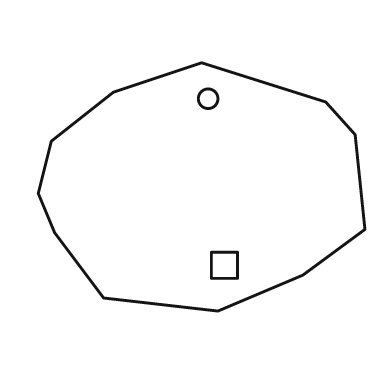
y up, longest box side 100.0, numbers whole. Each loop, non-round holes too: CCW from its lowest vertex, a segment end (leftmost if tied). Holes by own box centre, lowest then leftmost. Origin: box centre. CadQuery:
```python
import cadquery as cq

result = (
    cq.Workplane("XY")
    .moveTo(5.0, -38.0)
    .lineTo(31.0, -27.0)
    .lineTo(50.0, -13.0)
    .lineTo(47.0, 16.0)
    .lineTo(38.0, 26.0)
    .lineTo(0.0, 38.0)
    .lineTo(-27.0, 29.0)
    .lineTo(-46.0, 14.0)
    .lineTo(-50.0, -2.0)
    .lineTo(-45.0, -14.0)
    .lineTo(-30.0, -34.0)
    .close()
    .moveTo(3.0, -28.0)
    .lineTo(11.0, -28.0)
    .lineTo(11.0, -20.0)
    .lineTo(3.0, -20.0)
    .close()
    .moveTo(2.0, 27.0)
    .circle(3.0)
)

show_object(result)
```